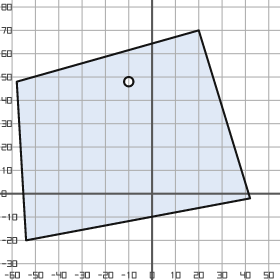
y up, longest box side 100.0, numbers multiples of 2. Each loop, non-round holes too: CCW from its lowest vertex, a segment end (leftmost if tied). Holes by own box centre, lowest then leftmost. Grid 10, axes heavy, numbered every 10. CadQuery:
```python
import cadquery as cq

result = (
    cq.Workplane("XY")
    .moveTo(-54.0, -20.0)
    .lineTo(42.0, -2.0)
    .lineTo(20.0, 70.0)
    .lineTo(-58.0, 48.0)
    .close()
    .moveTo(-10.0, 48.0)
    .circle(2.0)
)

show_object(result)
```